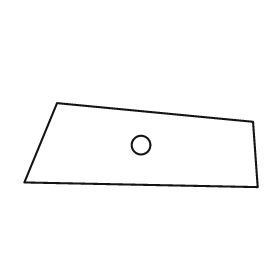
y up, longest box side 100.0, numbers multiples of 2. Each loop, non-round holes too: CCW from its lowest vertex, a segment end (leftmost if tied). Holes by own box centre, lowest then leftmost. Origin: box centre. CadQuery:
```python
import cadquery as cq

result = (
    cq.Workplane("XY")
    .moveTo(50.0, -18.0)
    .lineTo(48.0, 10.0)
    .lineTo(-36.0, 18.0)
    .lineTo(-50.0, -16.0)
    .close()
    .moveTo(0.0, 0.0)
    .circle(4.0)
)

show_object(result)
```